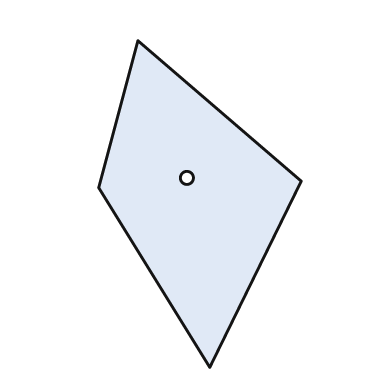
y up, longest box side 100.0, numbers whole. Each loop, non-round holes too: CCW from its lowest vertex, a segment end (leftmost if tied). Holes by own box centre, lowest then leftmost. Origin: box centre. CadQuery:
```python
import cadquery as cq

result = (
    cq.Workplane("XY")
    .moveTo(3.0, -50.0)
    .lineTo(31.0, 7.0)
    .lineTo(-19.0, 50.0)
    .lineTo(-31.0, 5.0)
    .close()
    .moveTo(-4.0, 8.0)
    .circle(2.0)
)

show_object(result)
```